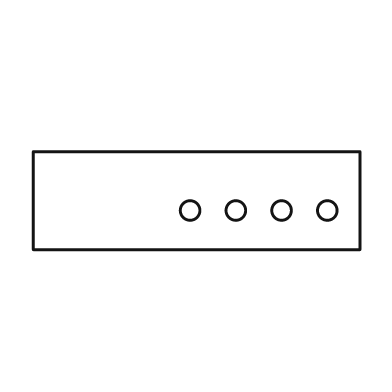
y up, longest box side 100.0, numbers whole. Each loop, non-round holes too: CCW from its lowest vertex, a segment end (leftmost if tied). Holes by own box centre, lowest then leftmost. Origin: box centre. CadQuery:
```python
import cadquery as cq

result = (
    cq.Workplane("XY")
    .moveTo(-50.0, -15.0)
    .lineTo(50.0, -15.0)
    .lineTo(50.0, 15.0)
    .lineTo(-50.0, 15.0)
    .close()
    .moveTo(-2.0, -3.0)
    .circle(3.0)
    .moveTo(12.0, -3.0)
    .circle(3.0)
    .moveTo(26.0, -3.0)
    .circle(3.0)
    .moveTo(40.0, -3.0)
    .circle(3.0)
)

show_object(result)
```